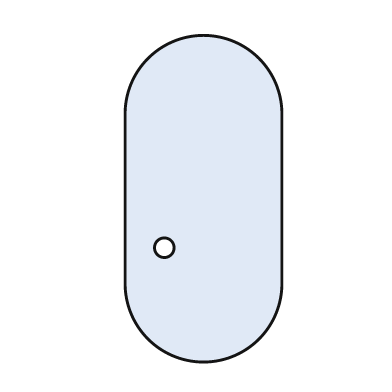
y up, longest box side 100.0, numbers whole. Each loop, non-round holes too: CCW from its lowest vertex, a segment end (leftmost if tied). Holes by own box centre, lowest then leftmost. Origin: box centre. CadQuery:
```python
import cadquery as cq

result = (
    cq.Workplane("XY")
    .moveTo(-24.0, -26.0)
    .threePointArc((0.0, -50.0), (24.0, -26.0))
    .lineTo(24.0, 26.0)
    .threePointArc((0.0, 50.0), (-24.0, 26.0))
    .close()
    .moveTo(-12.0, -15.0)
    .circle(3.0)
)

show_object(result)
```